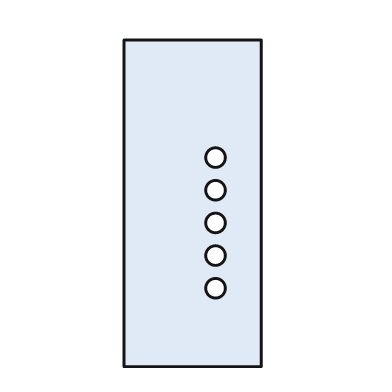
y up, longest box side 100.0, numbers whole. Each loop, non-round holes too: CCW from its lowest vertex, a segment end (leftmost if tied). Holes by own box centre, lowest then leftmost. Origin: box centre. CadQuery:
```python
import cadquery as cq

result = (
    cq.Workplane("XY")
    .moveTo(-21.0, -50.0)
    .lineTo(21.0, -50.0)
    .lineTo(21.0, 50.0)
    .lineTo(-21.0, 50.0)
    .close()
    .moveTo(7.0, -26.0)
    .circle(3.0)
    .moveTo(7.0, -16.0)
    .circle(3.0)
    .moveTo(7.0, -6.0)
    .circle(3.0)
    .moveTo(7.0, 4.0)
    .circle(3.0)
    .moveTo(7.0, 14.0)
    .circle(3.0)
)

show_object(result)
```